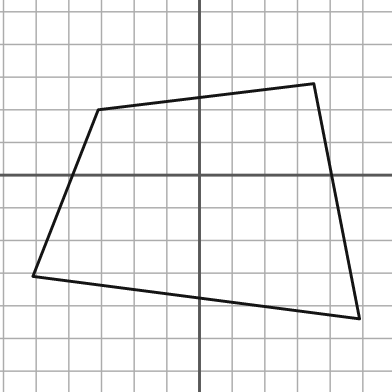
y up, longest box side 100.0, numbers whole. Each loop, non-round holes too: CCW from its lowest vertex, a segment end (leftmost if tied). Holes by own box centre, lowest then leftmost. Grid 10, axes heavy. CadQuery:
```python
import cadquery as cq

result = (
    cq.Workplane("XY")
    .moveTo(49.0, -44.0)
    .lineTo(35.0, 28.0)
    .lineTo(-31.0, 20.0)
    .lineTo(-51.0, -31.0)
    .close()
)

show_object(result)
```